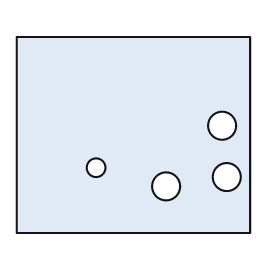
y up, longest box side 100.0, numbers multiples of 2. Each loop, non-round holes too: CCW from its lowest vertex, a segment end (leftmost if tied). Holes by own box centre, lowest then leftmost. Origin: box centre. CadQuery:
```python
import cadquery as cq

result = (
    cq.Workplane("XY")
    .moveTo(-50.0, -42.0)
    .lineTo(50.0, -42.0)
    .lineTo(50.0, 42.0)
    .lineTo(-50.0, 42.0)
    .close()
    .moveTo(14.0, -22.0)
    .circle(6.0)
    .moveTo(40.0, -18.0)
    .circle(6.0)
    .moveTo(-16.0, -14.0)
    .circle(4.0)
    .moveTo(38.0, 4.0)
    .circle(6.0)
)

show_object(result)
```